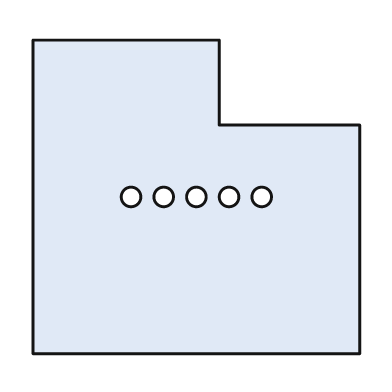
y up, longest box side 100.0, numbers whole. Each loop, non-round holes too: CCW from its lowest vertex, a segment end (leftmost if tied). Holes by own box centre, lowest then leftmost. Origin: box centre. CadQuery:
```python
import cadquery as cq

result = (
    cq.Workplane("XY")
    .moveTo(-50.0, -48.0)
    .lineTo(50.0, -48.0)
    .lineTo(50.0, 22.0)
    .lineTo(7.0, 22.0)
    .lineTo(7.0, 48.0)
    .lineTo(-50.0, 48.0)
    .close()
    .moveTo(-20.0, 0.0)
    .circle(3.0)
    .moveTo(-10.0, 0.0)
    .circle(3.0)
    .moveTo(0.0, 0.0)
    .circle(3.0)
    .moveTo(10.0, 0.0)
    .circle(3.0)
    .moveTo(20.0, 0.0)
    .circle(3.0)
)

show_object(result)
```